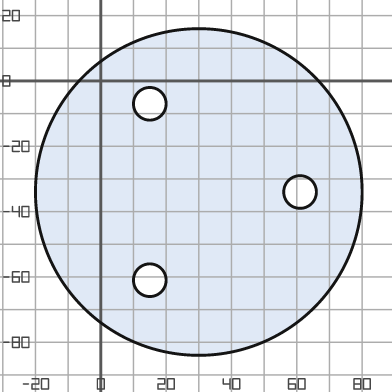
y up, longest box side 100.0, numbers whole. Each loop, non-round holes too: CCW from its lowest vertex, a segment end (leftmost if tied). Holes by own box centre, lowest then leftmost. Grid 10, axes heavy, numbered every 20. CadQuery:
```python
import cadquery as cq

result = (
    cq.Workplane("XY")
    .moveTo(30.0, -34.0)
    .circle(50.0)
    .moveTo(15.0, -61.0)
    .circle(5.0)
    .moveTo(61.0, -34.0)
    .circle(5.0)
    .moveTo(15.0, -7.0)
    .circle(5.0)
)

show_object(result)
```